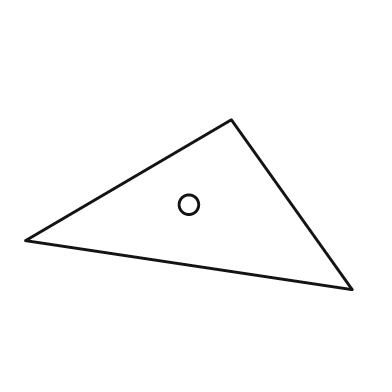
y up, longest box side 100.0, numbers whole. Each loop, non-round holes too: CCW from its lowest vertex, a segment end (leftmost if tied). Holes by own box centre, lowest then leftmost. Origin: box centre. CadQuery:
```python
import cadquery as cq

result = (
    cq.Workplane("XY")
    .moveTo(50.0, -26.0)
    .lineTo(13.0, 26.0)
    .lineTo(-50.0, -11.0)
    .close()
    .moveTo(0.0, 0.0)
    .circle(3.0)
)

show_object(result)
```